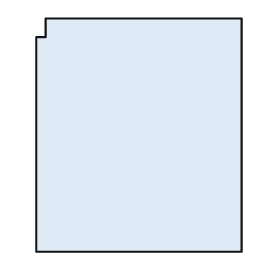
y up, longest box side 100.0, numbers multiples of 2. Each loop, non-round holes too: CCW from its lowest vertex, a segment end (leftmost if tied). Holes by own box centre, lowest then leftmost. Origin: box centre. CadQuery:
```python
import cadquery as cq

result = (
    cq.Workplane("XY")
    .moveTo(-44.0, -50.0)
    .lineTo(44.0, -50.0)
    .lineTo(44.0, 50.0)
    .lineTo(-40.0, 50.0)
    .lineTo(-40.0, 42.0)
    .lineTo(-44.0, 42.0)
    .close()
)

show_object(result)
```